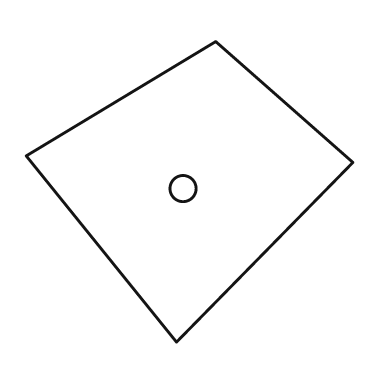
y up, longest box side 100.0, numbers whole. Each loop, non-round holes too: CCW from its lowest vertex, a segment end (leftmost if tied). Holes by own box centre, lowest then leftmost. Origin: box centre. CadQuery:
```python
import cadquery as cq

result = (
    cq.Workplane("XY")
    .moveTo(-4.0, -46.0)
    .lineTo(50.0, 9.0)
    .lineTo(8.0, 46.0)
    .lineTo(-50.0, 11.0)
    .close()
    .moveTo(-2.0, 1.0)
    .circle(4.0)
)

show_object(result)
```